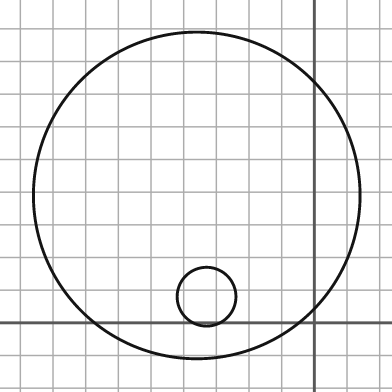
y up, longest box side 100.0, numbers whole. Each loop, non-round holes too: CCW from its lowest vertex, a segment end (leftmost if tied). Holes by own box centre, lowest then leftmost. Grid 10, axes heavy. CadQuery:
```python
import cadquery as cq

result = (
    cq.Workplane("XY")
    .moveTo(-36.0, 39.0)
    .circle(50.0)
    .moveTo(-33.0, 8.0)
    .circle(9.0)
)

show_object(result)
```